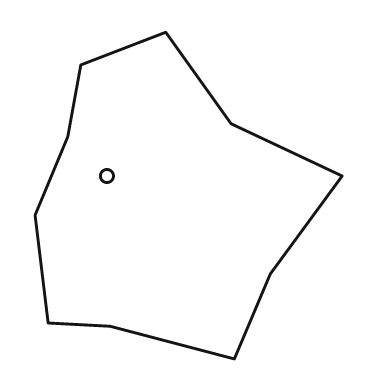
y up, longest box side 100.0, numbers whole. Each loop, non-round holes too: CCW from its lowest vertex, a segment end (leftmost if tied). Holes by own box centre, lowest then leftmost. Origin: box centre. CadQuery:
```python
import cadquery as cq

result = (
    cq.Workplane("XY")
    .moveTo(14.0, -50.0)
    .lineTo(25.0, -24.0)
    .lineTo(47.0, 6.0)
    .lineTo(13.0, 22.0)
    .lineTo(-7.0, 50.0)
    .lineTo(-33.0, 40.0)
    .lineTo(-37.0, 18.0)
    .lineTo(-47.0, -6.0)
    .lineTo(-43.0, -39.0)
    .lineTo(-24.0, -40.0)
    .close()
    .moveTo(-25.0, 6.0)
    .circle(2.0)
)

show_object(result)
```